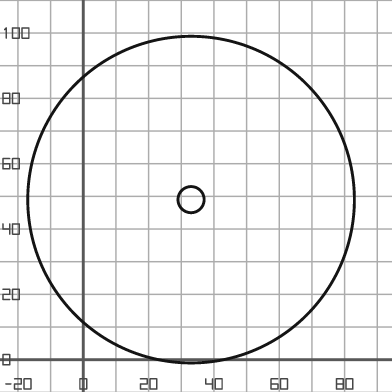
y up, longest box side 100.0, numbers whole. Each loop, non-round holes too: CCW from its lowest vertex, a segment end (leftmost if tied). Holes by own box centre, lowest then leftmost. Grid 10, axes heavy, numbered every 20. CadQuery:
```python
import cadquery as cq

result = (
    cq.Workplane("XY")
    .moveTo(33.0, 49.0)
    .circle(50.0)
    .moveTo(33.0, 49.0)
    .circle(4.0)
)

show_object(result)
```